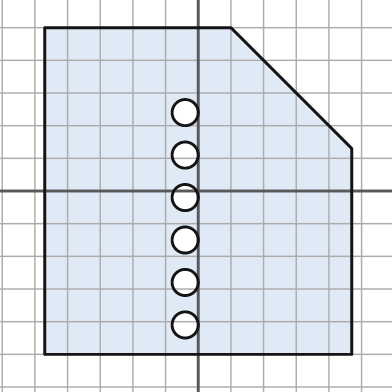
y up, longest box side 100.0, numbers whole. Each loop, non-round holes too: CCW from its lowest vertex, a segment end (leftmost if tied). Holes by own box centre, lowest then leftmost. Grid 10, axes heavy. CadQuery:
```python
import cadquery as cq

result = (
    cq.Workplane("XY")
    .moveTo(-47.0, -50.0)
    .lineTo(47.0, -50.0)
    .lineTo(47.0, 13.0)
    .lineTo(10.0, 50.0)
    .lineTo(-47.0, 50.0)
    .close()
    .moveTo(-4.0, -41.0)
    .circle(4.0)
    .moveTo(-4.0, -28.0)
    .circle(4.0)
    .moveTo(-4.0, -15.0)
    .circle(4.0)
    .moveTo(-4.0, -2.0)
    .circle(4.0)
    .moveTo(-4.0, 11.0)
    .circle(4.0)
    .moveTo(-4.0, 24.0)
    .circle(4.0)
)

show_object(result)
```